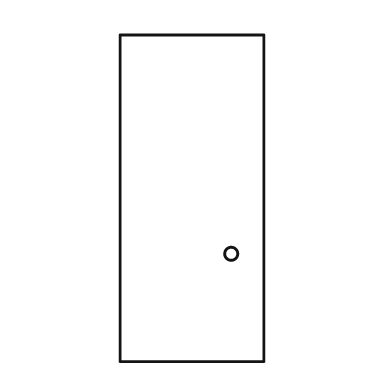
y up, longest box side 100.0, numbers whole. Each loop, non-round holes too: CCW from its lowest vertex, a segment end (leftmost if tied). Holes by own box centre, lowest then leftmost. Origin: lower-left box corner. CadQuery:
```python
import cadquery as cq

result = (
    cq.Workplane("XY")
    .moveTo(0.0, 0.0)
    .lineTo(44.0, 0.0)
    .lineTo(44.0, 100.0)
    .lineTo(0.0, 100.0)
    .close()
    .moveTo(34.0, 33.0)
    .circle(2.0)
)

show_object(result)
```